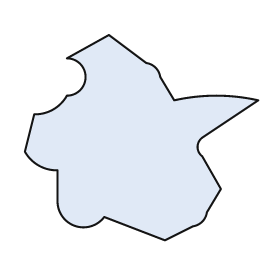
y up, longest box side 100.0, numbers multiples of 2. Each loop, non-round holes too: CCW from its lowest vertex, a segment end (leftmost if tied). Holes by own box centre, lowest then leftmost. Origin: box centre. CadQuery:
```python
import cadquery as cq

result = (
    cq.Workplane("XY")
    .moveTo(10.0, -44.0)
    .lineTo(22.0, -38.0)
    .threePointArc((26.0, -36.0), (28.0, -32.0))
    .lineTo(34.0, -22.0)
    .lineTo(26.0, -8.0)
    .threePointArc((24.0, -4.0), (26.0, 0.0))
    .lineTo(50.0, 16.0)
    .threePointArc((32.0, 18.0), (14.0, 16.0))
    .lineTo(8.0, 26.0)
    .threePointArc((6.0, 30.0), (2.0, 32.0))
    .lineTo(-14.0, 44.0)
    .lineTo(-32.0, 34.0)
    .threePointArc((-24.0, 26.0), (-32.0, 18.0))
    .threePointArc((-38.0, 12.0), (-46.0, 10.0))
    .lineTo(-50.0, -6.0)
    .threePointArc((-44.0, -12.0), (-36.0, -14.0))
    .lineTo(-36.0, -28.0)
    .threePointArc((-28.0, -38.0), (-16.0, -34.0))
    .close()
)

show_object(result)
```